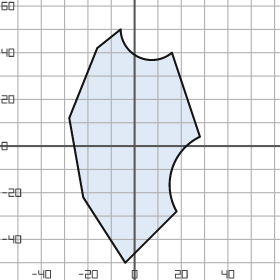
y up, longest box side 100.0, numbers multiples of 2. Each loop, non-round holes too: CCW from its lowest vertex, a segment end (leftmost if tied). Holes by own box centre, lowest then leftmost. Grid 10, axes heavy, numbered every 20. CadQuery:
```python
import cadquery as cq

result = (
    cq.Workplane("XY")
    .moveTo(-4.0, -50.0)
    .lineTo(18.0, -28.0)
    .threePointArc((16.0, -10.0), (28.0, 4.0))
    .lineTo(16.0, 40.0)
    .threePointArc((2.0, 38.0), (-6.0, 50.0))
    .lineTo(-16.0, 42.0)
    .lineTo(-28.0, 12.0)
    .lineTo(-22.0, -22.0)
    .close()
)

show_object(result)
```